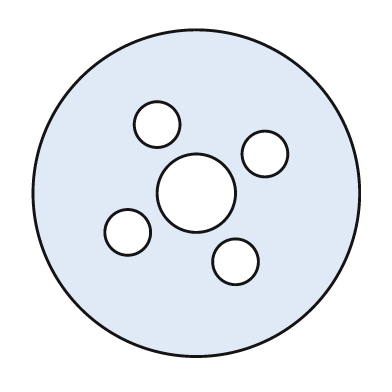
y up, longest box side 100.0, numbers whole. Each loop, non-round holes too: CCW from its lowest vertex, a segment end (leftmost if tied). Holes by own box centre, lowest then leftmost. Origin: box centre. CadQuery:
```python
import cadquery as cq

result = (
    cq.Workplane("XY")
    .moveTo(0.0, 0.0)
    .circle(50.0)
    .moveTo(12.0, -21.0)
    .circle(7.0)
    .moveTo(-21.0, -12.0)
    .circle(7.0)
    .moveTo(0.0, 0.0)
    .circle(12.0)
    .moveTo(21.0, 12.0)
    .circle(7.0)
    .moveTo(-12.0, 21.0)
    .circle(7.0)
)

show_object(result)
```